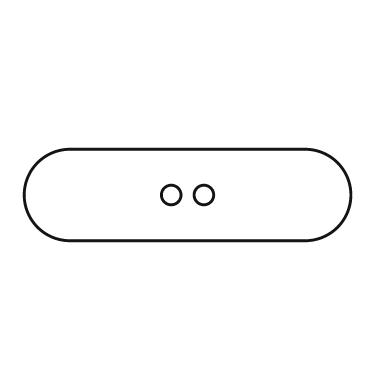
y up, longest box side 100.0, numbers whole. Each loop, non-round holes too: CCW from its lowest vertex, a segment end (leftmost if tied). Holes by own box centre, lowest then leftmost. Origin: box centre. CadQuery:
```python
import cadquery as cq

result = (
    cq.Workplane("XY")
    .moveTo(-36.0, -14.0)
    .lineTo(36.0, -14.0)
    .threePointArc((50.0, 0.0), (36.0, 14.0))
    .lineTo(-36.0, 14.0)
    .threePointArc((-50.0, 0.0), (-36.0, -14.0))
    .close()
    .moveTo(-5.0, 0.0)
    .circle(3.0)
    .moveTo(5.0, 0.0)
    .circle(3.0)
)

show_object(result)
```